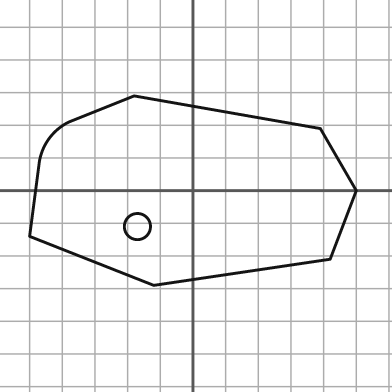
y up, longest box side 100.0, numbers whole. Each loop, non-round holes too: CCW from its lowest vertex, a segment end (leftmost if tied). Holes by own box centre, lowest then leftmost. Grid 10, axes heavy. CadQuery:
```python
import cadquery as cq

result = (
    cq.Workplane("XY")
    .moveTo(-12.0, -29.0)
    .lineTo(42.0, -21.0)
    .lineTo(50.0, 0.0)
    .lineTo(39.0, 19.0)
    .lineTo(-18.0, 29.0)
    .lineTo(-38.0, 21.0)
    .threePointArc((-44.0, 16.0), (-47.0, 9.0))
    .lineTo(-50.0, -14.0)
    .close()
    .moveTo(-17.0, -11.0)
    .circle(4.0)
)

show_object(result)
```